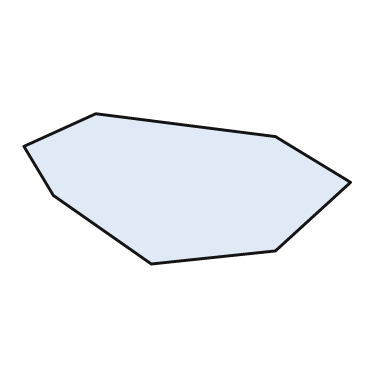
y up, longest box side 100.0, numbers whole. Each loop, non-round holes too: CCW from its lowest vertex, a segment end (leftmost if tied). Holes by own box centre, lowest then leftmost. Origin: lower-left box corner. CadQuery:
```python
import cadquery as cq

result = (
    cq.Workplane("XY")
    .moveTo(39.0, 0.0)
    .lineTo(77.0, 4.0)
    .lineTo(100.0, 25.0)
    .lineTo(77.0, 39.0)
    .lineTo(22.0, 46.0)
    .lineTo(0.0, 36.0)
    .lineTo(9.0, 21.0)
    .close()
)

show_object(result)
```